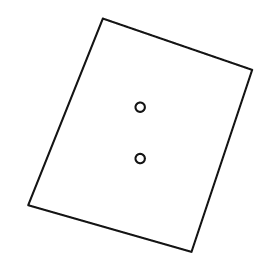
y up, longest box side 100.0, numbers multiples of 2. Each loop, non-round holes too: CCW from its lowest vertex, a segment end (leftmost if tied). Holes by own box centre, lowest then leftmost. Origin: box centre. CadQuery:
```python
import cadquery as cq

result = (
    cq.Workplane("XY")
    .moveTo(22.0, -50.0)
    .lineTo(48.0, 28.0)
    .lineTo(-16.0, 50.0)
    .lineTo(-48.0, -30.0)
    .close()
    .moveTo(0.0, -10.0)
    .circle(2.0)
    .moveTo(0.0, 12.0)
    .circle(2.0)
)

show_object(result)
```